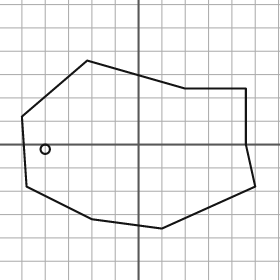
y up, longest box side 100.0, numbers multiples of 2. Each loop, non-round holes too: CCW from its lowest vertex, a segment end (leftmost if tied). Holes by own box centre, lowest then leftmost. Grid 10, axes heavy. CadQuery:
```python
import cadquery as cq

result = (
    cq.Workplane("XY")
    .moveTo(10.0, -36.0)
    .lineTo(50.0, -18.0)
    .lineTo(46.0, 0.0)
    .lineTo(46.0, 24.0)
    .lineTo(20.0, 24.0)
    .lineTo(-22.0, 36.0)
    .lineTo(-50.0, 12.0)
    .lineTo(-48.0, -18.0)
    .lineTo(-20.0, -32.0)
    .close()
    .moveTo(-40.0, -2.0)
    .circle(2.0)
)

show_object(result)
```